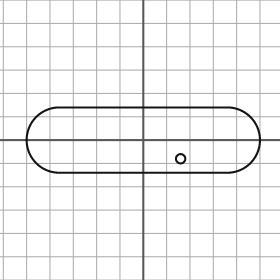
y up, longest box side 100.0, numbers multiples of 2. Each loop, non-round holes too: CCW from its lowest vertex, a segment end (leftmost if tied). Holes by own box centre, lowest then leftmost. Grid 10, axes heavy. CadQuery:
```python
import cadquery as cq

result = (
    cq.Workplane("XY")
    .moveTo(-36.0, -14.0)
    .lineTo(36.0, -14.0)
    .threePointArc((50.0, 0.0), (36.0, 14.0))
    .lineTo(-36.0, 14.0)
    .threePointArc((-50.0, 0.0), (-36.0, -14.0))
    .close()
    .moveTo(16.0, -8.0)
    .circle(2.0)
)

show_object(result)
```